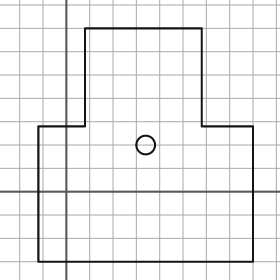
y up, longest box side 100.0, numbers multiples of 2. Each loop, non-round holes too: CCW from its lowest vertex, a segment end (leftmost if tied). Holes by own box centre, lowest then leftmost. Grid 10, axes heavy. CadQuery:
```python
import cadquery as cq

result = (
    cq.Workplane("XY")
    .moveTo(-12.0, -30.0)
    .lineTo(80.0, -30.0)
    .lineTo(80.0, 28.0)
    .lineTo(58.0, 28.0)
    .lineTo(58.0, 70.0)
    .lineTo(8.0, 70.0)
    .lineTo(8.0, 28.0)
    .lineTo(-12.0, 28.0)
    .close()
    .moveTo(34.0, 20.0)
    .circle(4.0)
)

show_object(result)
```